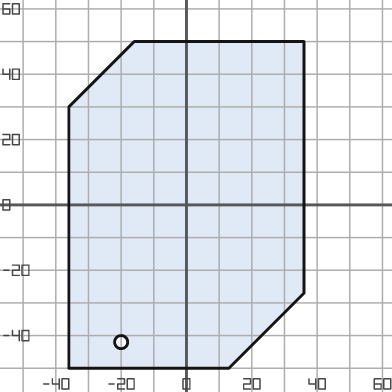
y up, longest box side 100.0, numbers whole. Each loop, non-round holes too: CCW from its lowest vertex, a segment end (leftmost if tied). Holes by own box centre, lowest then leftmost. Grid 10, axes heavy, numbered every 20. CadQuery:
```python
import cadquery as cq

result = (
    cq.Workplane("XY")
    .moveTo(-36.0, -50.0)
    .lineTo(13.0, -50.0)
    .lineTo(36.0, -27.0)
    .lineTo(36.0, 50.0)
    .lineTo(-16.0, 50.0)
    .lineTo(-36.0, 30.0)
    .close()
    .moveTo(-20.0, -42.0)
    .circle(2.0)
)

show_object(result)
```